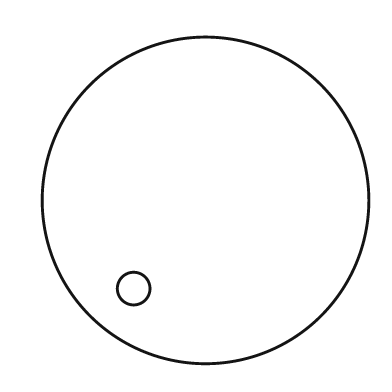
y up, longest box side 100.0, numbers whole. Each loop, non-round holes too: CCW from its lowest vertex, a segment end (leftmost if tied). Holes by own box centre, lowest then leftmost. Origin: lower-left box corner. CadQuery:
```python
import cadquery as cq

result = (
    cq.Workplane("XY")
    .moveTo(50.0, 50.0)
    .circle(50.0)
    .moveTo(28.0, 23.0)
    .circle(5.0)
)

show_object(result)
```